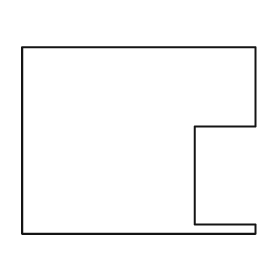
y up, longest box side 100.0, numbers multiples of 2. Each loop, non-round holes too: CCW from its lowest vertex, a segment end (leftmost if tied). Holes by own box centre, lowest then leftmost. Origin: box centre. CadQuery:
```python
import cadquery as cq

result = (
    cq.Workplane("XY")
    .moveTo(-50.0, -40.0)
    .lineTo(50.0, -40.0)
    .lineTo(50.0, -36.0)
    .lineTo(24.0, -36.0)
    .lineTo(24.0, 6.0)
    .lineTo(50.0, 6.0)
    .lineTo(50.0, 40.0)
    .lineTo(-50.0, 40.0)
    .close()
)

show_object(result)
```